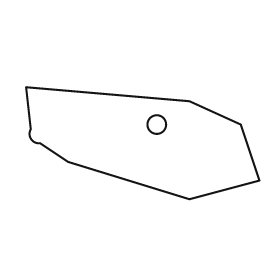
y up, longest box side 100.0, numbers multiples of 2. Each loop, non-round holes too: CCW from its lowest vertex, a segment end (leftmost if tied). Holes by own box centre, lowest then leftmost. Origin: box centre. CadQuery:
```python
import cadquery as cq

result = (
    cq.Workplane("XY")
    .moveTo(20.0, -24.0)
    .lineTo(50.0, -16.0)
    .lineTo(42.0, 8.0)
    .lineTo(20.0, 18.0)
    .lineTo(-50.0, 24.0)
    .lineTo(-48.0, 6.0)
    .threePointArc((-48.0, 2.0), (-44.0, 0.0))
    .lineTo(-32.0, -8.0)
    .close()
    .moveTo(6.0, 8.0)
    .circle(4.0)
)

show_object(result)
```